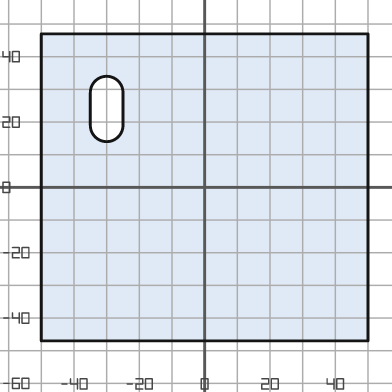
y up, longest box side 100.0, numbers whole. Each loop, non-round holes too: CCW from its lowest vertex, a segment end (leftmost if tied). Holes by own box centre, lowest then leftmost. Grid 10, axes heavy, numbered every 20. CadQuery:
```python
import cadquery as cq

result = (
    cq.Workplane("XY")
    .moveTo(-50.0, -47.0)
    .lineTo(50.0, -47.0)
    .lineTo(50.0, 47.0)
    .lineTo(-50.0, 47.0)
    .close()
    .moveTo(-35.0, 19.0)
    .threePointArc((-30.0, 14.0), (-25.0, 19.0))
    .lineTo(-25.0, 29.0)
    .threePointArc((-30.0, 34.0), (-35.0, 29.0))
    .close()
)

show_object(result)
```